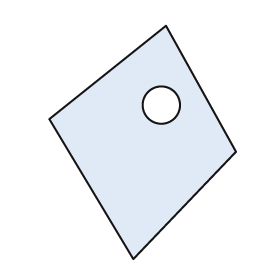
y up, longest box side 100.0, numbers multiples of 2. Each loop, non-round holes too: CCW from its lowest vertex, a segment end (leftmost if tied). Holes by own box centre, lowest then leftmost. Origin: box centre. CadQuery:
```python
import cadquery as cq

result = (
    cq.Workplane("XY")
    .moveTo(-4.0, -50.0)
    .lineTo(40.0, -4.0)
    .lineTo(10.0, 50.0)
    .lineTo(-40.0, 10.0)
    .close()
    .moveTo(8.0, 16.0)
    .circle(8.0)
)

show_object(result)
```